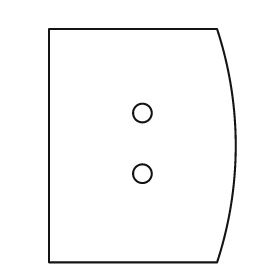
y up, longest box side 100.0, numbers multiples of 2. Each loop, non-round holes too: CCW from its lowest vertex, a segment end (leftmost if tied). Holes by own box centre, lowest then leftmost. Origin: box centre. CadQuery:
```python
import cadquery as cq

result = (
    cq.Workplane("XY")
    .moveTo(-40.0, -50.0)
    .lineTo(32.0, -50.0)
    .threePointArc((40.0, 0.0), (32.0, 50.0))
    .lineTo(-40.0, 50.0)
    .close()
    .moveTo(0.0, -12.0)
    .circle(4.0)
    .moveTo(0.0, 14.0)
    .circle(4.0)
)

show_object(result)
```